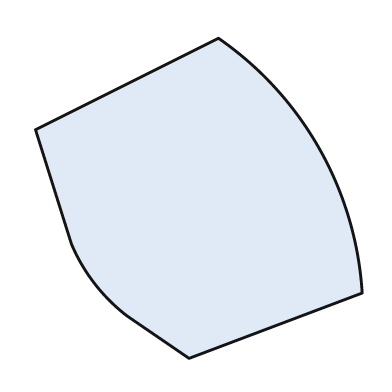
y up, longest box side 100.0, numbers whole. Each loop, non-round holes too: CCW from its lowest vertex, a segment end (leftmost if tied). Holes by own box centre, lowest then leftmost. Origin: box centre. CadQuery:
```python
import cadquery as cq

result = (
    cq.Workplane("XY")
    .moveTo(-3.0, -49.0)
    .lineTo(50.0, -29.0)
    .threePointArc((37.0, 15.0), (6.0, 49.0))
    .lineTo(-50.0, 21.0)
    .lineTo(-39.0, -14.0)
    .threePointArc((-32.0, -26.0), (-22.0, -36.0))
    .close()
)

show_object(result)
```